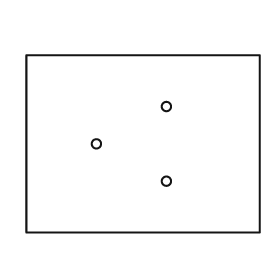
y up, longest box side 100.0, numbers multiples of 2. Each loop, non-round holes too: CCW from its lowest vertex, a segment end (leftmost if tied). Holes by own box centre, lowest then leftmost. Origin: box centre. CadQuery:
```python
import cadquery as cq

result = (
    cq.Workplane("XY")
    .moveTo(-50.0, -38.0)
    .lineTo(50.0, -38.0)
    .lineTo(50.0, 38.0)
    .lineTo(-50.0, 38.0)
    .close()
    .moveTo(10.0, -16.0)
    .circle(2.0)
    .moveTo(-20.0, 0.0)
    .circle(2.0)
    .moveTo(10.0, 16.0)
    .circle(2.0)
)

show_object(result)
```